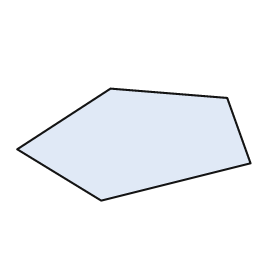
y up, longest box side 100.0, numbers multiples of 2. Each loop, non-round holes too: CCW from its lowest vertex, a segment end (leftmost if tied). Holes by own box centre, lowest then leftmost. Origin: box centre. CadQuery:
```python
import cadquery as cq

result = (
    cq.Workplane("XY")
    .moveTo(-14.0, -24.0)
    .lineTo(50.0, -8.0)
    .lineTo(40.0, 20.0)
    .lineTo(-10.0, 24.0)
    .lineTo(-50.0, -2.0)
    .close()
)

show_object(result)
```